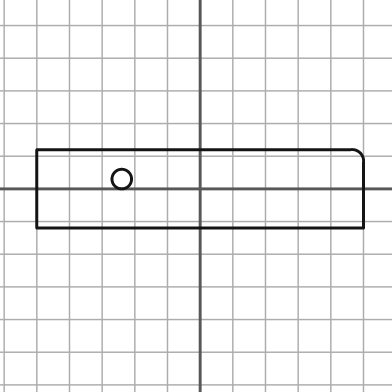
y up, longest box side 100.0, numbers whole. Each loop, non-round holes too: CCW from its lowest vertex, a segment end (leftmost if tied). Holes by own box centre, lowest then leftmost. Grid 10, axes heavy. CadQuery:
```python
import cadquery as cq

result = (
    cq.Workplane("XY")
    .moveTo(-50.0, -12.0)
    .lineTo(50.0, -12.0)
    .lineTo(50.0, 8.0)
    .threePointArc((49.0, 11.0), (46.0, 12.0))
    .lineTo(-50.0, 12.0)
    .close()
    .moveTo(-24.0, 3.0)
    .circle(3.0)
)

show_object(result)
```